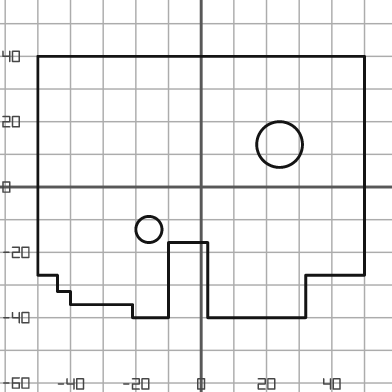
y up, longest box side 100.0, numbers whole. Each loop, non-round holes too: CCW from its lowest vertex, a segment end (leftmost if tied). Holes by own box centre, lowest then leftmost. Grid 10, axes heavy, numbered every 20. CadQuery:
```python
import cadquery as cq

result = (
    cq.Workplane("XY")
    .moveTo(-21.0, -40.0)
    .lineTo(-10.0, -40.0)
    .lineTo(-10.0, -17.0)
    .lineTo(2.0, -17.0)
    .lineTo(2.0, -40.0)
    .lineTo(32.0, -40.0)
    .lineTo(32.0, -27.0)
    .lineTo(50.0, -27.0)
    .lineTo(50.0, 40.0)
    .lineTo(-50.0, 40.0)
    .lineTo(-50.0, -27.0)
    .lineTo(-44.0, -27.0)
    .lineTo(-44.0, -32.0)
    .lineTo(-40.0, -32.0)
    .lineTo(-40.0, -36.0)
    .lineTo(-21.0, -36.0)
    .close()
    .moveTo(-16.0, -13.0)
    .circle(4.0)
    .moveTo(24.0, 13.0)
    .circle(7.0)
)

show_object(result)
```